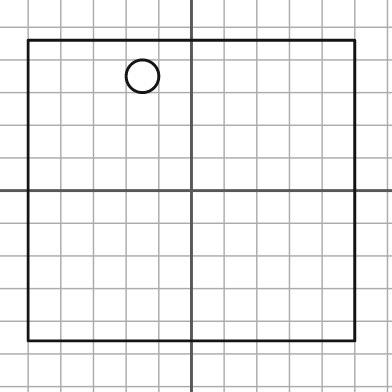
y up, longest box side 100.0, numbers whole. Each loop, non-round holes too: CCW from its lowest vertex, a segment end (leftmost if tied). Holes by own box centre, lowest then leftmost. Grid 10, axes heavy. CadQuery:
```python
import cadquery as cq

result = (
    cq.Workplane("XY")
    .moveTo(-50.0, -46.0)
    .lineTo(50.0, -46.0)
    .lineTo(50.0, 46.0)
    .lineTo(-50.0, 46.0)
    .close()
    .moveTo(-15.0, 35.0)
    .circle(5.0)
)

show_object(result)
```